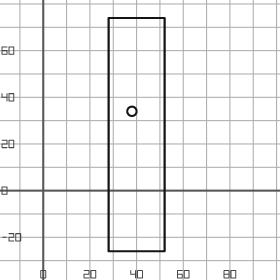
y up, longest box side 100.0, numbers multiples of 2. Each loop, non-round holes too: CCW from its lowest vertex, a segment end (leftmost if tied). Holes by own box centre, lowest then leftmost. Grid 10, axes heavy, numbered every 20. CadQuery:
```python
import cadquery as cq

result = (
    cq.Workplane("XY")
    .moveTo(28.0, -26.0)
    .lineTo(52.0, -26.0)
    .lineTo(52.0, 74.0)
    .lineTo(28.0, 74.0)
    .close()
    .moveTo(38.0, 34.0)
    .circle(2.0)
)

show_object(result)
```